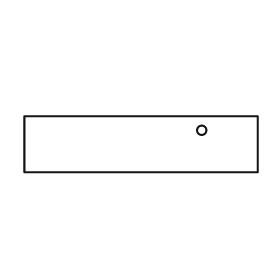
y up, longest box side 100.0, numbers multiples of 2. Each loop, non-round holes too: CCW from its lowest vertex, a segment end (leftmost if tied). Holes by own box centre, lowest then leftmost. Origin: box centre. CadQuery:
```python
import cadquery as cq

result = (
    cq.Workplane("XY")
    .moveTo(-50.0, -12.0)
    .lineTo(50.0, -12.0)
    .lineTo(50.0, 12.0)
    .lineTo(-50.0, 12.0)
    .close()
    .moveTo(26.0, 6.0)
    .circle(2.0)
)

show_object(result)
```